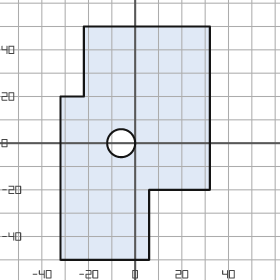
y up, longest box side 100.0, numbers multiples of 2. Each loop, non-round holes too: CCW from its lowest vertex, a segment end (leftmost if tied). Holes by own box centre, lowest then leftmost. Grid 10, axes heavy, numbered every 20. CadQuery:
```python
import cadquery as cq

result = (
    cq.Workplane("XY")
    .moveTo(-32.0, -50.0)
    .lineTo(6.0, -50.0)
    .lineTo(6.0, -20.0)
    .lineTo(32.0, -20.0)
    .lineTo(32.0, 50.0)
    .lineTo(-22.0, 50.0)
    .lineTo(-22.0, 20.0)
    .lineTo(-32.0, 20.0)
    .close()
    .moveTo(-6.0, 0.0)
    .circle(6.0)
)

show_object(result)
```